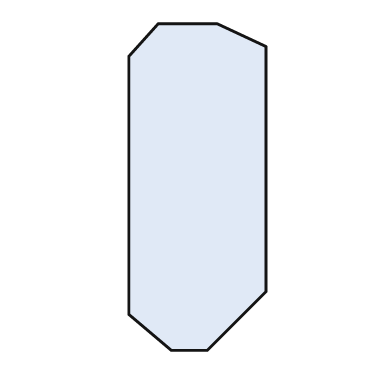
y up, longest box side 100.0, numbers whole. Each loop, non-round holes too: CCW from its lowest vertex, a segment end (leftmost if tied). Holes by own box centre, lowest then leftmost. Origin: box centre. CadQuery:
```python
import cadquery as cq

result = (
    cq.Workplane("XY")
    .moveTo(-8.0, -50.0)
    .lineTo(3.0, -50.0)
    .lineTo(21.0, -32.0)
    .lineTo(21.0, 43.0)
    .lineTo(6.0, 50.0)
    .lineTo(-12.0, 50.0)
    .lineTo(-21.0, 40.0)
    .lineTo(-21.0, -39.0)
    .close()
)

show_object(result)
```